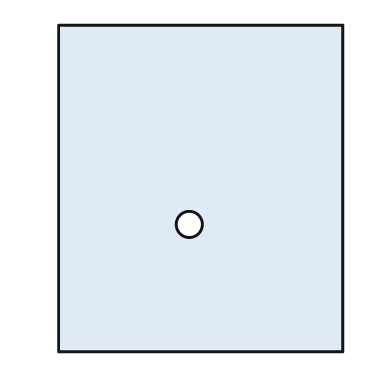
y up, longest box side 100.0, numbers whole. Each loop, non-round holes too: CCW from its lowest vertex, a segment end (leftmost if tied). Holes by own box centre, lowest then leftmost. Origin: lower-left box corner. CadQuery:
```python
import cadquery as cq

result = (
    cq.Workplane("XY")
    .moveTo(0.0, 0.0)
    .lineTo(87.0, 0.0)
    .lineTo(87.0, 100.0)
    .lineTo(0.0, 100.0)
    .close()
    .moveTo(40.0, 39.0)
    .circle(4.0)
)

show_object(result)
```